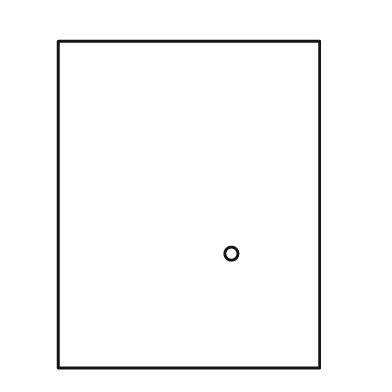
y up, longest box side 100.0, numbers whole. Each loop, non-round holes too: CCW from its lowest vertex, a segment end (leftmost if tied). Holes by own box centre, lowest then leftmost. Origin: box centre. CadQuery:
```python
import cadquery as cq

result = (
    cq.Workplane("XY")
    .moveTo(-40.0, -50.0)
    .lineTo(40.0, -50.0)
    .lineTo(40.0, 50.0)
    .lineTo(-40.0, 50.0)
    .close()
    .moveTo(13.0, -15.0)
    .circle(2.0)
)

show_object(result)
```